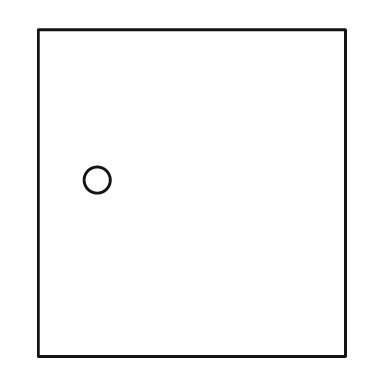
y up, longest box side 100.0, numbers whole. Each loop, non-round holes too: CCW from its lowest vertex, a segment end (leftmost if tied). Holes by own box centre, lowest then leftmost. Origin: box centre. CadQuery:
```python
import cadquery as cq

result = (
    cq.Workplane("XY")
    .moveTo(-47.0, -50.0)
    .lineTo(47.0, -50.0)
    .lineTo(47.0, 50.0)
    .lineTo(-47.0, 50.0)
    .close()
    .moveTo(-29.0, 4.0)
    .circle(4.0)
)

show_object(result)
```